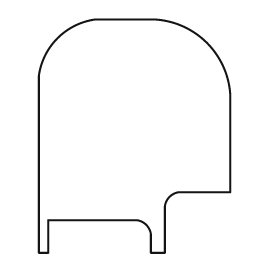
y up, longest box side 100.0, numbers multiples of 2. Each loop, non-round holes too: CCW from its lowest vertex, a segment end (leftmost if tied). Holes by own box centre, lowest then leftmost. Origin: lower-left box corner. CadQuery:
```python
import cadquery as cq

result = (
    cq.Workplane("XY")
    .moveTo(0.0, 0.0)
    .lineTo(4.0, 0.0)
    .lineTo(4.0, 14.0)
    .lineTo(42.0, 14.0)
    .threePointArc((46.0, 12.0), (48.0, 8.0))
    .lineTo(48.0, 0.0)
    .lineTo(54.0, 0.0)
    .lineTo(54.0, 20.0)
    .threePointArc((56.0, 24.0), (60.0, 26.0))
    .lineTo(82.0, 26.0)
    .lineTo(82.0, 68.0)
    .threePointArc((72.0, 90.0), (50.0, 100.0))
    .lineTo(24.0, 100.0)
    .threePointArc((8.0, 92.0), (0.0, 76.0))
    .close()
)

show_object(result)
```